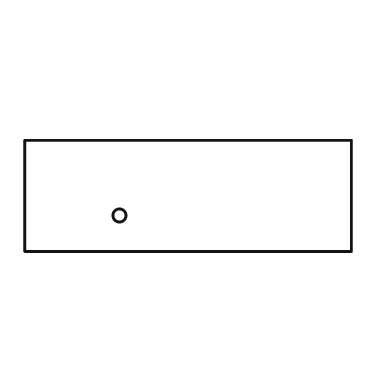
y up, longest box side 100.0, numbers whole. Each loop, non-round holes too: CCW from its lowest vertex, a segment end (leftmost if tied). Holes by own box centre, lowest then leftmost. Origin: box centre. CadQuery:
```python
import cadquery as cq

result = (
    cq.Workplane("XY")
    .moveTo(-50.0, -17.0)
    .lineTo(50.0, -17.0)
    .lineTo(50.0, 17.0)
    .lineTo(-50.0, 17.0)
    .close()
    .moveTo(-21.0, -6.0)
    .circle(2.0)
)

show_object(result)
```